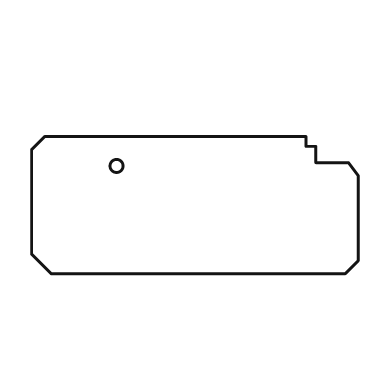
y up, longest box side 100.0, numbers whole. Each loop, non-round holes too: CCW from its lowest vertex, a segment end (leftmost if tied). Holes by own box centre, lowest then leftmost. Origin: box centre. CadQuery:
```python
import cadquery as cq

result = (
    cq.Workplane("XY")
    .moveTo(-44.0, -21.0)
    .lineTo(46.0, -21.0)
    .lineTo(50.0, -17.0)
    .lineTo(50.0, 9.0)
    .lineTo(47.0, 13.0)
    .lineTo(37.0, 13.0)
    .lineTo(37.0, 18.0)
    .lineTo(34.0, 18.0)
    .lineTo(34.0, 21.0)
    .lineTo(-46.0, 21.0)
    .lineTo(-50.0, 17.0)
    .lineTo(-50.0, -15.0)
    .close()
    .moveTo(-24.0, 12.0)
    .circle(2.0)
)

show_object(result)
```